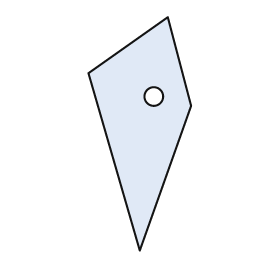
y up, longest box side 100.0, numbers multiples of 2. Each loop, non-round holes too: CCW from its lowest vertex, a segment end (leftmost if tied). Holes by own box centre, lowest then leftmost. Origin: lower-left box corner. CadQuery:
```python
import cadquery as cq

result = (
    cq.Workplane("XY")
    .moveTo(22.0, 0.0)
    .lineTo(44.0, 62.0)
    .lineTo(34.0, 100.0)
    .lineTo(0.0, 76.0)
    .close()
    .moveTo(28.0, 66.0)
    .circle(4.0)
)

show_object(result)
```